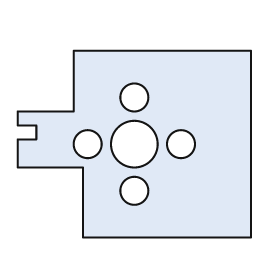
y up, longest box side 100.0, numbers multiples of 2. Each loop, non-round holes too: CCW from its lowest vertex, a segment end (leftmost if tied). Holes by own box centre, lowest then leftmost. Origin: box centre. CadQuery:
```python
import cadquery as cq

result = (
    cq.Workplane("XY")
    .moveTo(-22.0, -40.0)
    .lineTo(50.0, -40.0)
    .lineTo(50.0, 40.0)
    .lineTo(-26.0, 40.0)
    .lineTo(-26.0, 14.0)
    .lineTo(-50.0, 14.0)
    .lineTo(-50.0, 8.0)
    .lineTo(-42.0, 8.0)
    .lineTo(-42.0, 2.0)
    .lineTo(-50.0, 2.0)
    .lineTo(-50.0, -10.0)
    .lineTo(-22.0, -10.0)
    .close()
    .moveTo(0.0, -20.0)
    .circle(6.0)
    .moveTo(-20.0, 0.0)
    .circle(6.0)
    .moveTo(0.0, 0.0)
    .circle(10.0)
    .moveTo(20.0, 0.0)
    .circle(6.0)
    .moveTo(0.0, 20.0)
    .circle(6.0)
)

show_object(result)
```